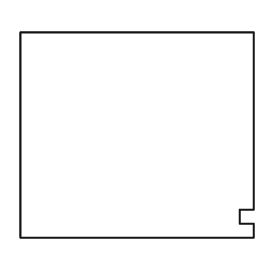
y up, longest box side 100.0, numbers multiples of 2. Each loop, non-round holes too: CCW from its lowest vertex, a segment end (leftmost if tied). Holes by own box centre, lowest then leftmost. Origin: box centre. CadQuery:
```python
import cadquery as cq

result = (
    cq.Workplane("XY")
    .moveTo(-50.0, -44.0)
    .lineTo(50.0, -44.0)
    .lineTo(50.0, -38.0)
    .lineTo(44.0, -38.0)
    .lineTo(44.0, -32.0)
    .lineTo(50.0, -32.0)
    .lineTo(50.0, 44.0)
    .lineTo(-50.0, 44.0)
    .close()
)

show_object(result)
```